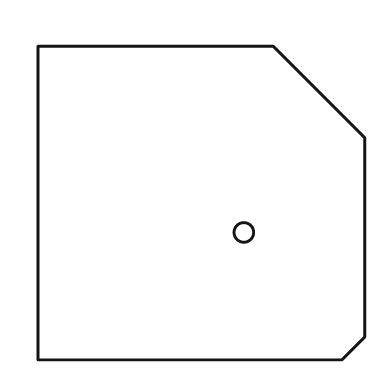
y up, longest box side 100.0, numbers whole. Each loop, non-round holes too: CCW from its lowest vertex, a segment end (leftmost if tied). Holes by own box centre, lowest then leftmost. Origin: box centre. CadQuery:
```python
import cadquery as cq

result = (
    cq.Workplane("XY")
    .moveTo(-50.0, -48.0)
    .lineTo(43.0, -48.0)
    .lineTo(50.0, -41.0)
    .lineTo(50.0, 20.0)
    .lineTo(22.0, 48.0)
    .lineTo(-50.0, 48.0)
    .close()
    .moveTo(13.0, -9.0)
    .circle(3.0)
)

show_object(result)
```